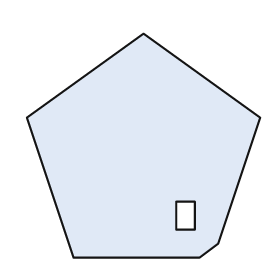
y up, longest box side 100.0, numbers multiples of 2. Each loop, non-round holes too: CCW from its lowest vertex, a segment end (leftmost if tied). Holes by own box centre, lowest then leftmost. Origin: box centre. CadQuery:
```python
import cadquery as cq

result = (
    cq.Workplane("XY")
    .moveTo(-30.0, -48.0)
    .lineTo(24.0, -48.0)
    .lineTo(32.0, -42.0)
    .lineTo(50.0, 12.0)
    .lineTo(0.0, 48.0)
    .lineTo(-50.0, 12.0)
    .close()
    .moveTo(14.0, -36.0)
    .lineTo(22.0, -36.0)
    .lineTo(22.0, -24.0)
    .lineTo(14.0, -24.0)
    .close()
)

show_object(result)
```